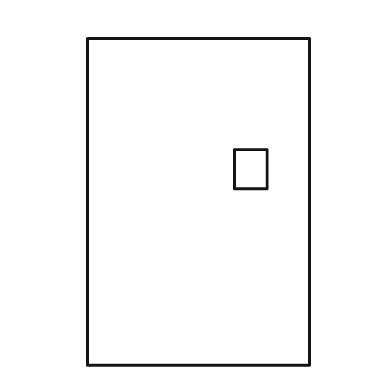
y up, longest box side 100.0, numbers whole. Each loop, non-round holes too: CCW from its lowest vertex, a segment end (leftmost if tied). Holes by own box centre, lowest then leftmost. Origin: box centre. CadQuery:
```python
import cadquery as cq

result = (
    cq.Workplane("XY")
    .moveTo(-34.0, -50.0)
    .lineTo(34.0, -50.0)
    .lineTo(34.0, 50.0)
    .lineTo(-34.0, 50.0)
    .close()
    .moveTo(11.0, 4.0)
    .lineTo(21.0, 4.0)
    .lineTo(21.0, 16.0)
    .lineTo(11.0, 16.0)
    .close()
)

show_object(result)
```